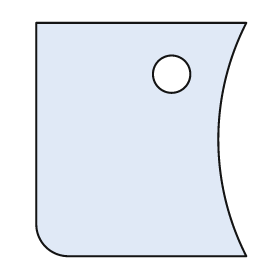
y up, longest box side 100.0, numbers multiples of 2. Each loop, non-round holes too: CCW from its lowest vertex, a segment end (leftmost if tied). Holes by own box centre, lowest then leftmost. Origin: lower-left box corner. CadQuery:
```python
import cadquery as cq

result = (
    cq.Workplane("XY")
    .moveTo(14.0, 0.0)
    .lineTo(90.0, 0.0)
    .threePointArc((78.0, 50.0), (90.0, 100.0))
    .lineTo(0.0, 100.0)
    .lineTo(0.0, 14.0)
    .threePointArc((4.0, 4.0), (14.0, 0.0))
    .close()
    .moveTo(58.0, 78.0)
    .circle(8.0)
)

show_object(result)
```